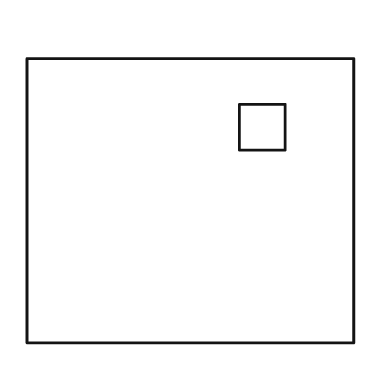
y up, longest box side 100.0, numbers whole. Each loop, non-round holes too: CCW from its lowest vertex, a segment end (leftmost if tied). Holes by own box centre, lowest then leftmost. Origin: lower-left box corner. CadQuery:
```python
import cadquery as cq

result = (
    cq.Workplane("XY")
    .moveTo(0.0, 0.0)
    .lineTo(100.0, 0.0)
    .lineTo(100.0, 87.0)
    .lineTo(0.0, 87.0)
    .close()
    .moveTo(65.0, 59.0)
    .lineTo(79.0, 59.0)
    .lineTo(79.0, 73.0)
    .lineTo(65.0, 73.0)
    .close()
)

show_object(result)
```